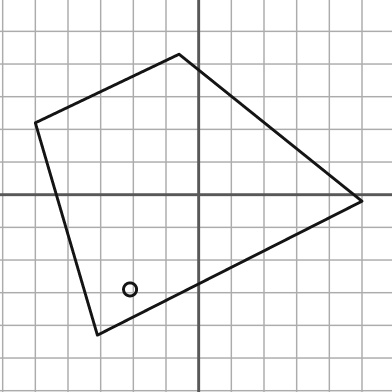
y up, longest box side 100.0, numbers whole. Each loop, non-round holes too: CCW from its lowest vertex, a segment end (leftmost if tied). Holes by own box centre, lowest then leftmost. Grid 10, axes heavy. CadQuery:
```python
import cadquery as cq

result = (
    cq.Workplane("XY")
    .moveTo(-31.0, -43.0)
    .lineTo(50.0, -2.0)
    .lineTo(-6.0, 43.0)
    .lineTo(-50.0, 22.0)
    .close()
    .moveTo(-21.0, -29.0)
    .circle(2.0)
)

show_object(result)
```